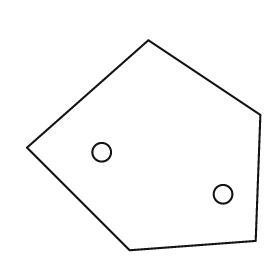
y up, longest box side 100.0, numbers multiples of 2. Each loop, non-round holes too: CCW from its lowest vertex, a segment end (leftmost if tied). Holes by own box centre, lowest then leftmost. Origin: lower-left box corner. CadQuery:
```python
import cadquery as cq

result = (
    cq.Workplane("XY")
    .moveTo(44.0, 0.0)
    .lineTo(98.0, 4.0)
    .lineTo(100.0, 58.0)
    .lineTo(52.0, 90.0)
    .lineTo(0.0, 44.0)
    .close()
    .moveTo(84.0, 24.0)
    .circle(4.0)
    .moveTo(32.0, 42.0)
    .circle(4.0)
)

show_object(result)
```